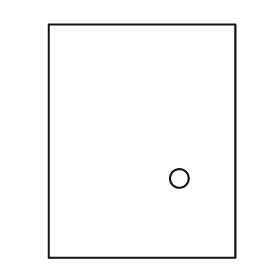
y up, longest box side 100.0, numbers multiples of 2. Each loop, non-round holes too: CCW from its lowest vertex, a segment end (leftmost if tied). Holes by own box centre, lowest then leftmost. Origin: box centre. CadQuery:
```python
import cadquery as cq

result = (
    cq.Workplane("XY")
    .moveTo(-40.0, -50.0)
    .lineTo(40.0, -50.0)
    .lineTo(40.0, 50.0)
    .lineTo(-40.0, 50.0)
    .close()
    .moveTo(16.0, -16.0)
    .circle(4.0)
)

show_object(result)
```